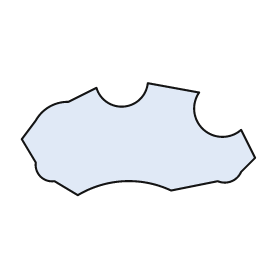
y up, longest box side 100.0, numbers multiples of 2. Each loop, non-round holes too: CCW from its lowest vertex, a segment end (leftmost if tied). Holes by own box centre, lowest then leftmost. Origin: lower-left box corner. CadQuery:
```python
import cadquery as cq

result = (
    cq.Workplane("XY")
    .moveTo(24.0, 0.0)
    .threePointArc((44.0, 6.0), (64.0, 2.0))
    .lineTo(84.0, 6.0)
    .threePointArc((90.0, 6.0), (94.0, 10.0))
    .lineTo(100.0, 16.0)
    .lineTo(94.0, 28.0)
    .threePointArc((78.0, 28.0), (76.0, 44.0))
    .lineTo(54.0, 48.0)
    .threePointArc((44.0, 38.0), (32.0, 46.0))
    .lineTo(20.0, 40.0)
    .threePointArc((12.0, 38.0), (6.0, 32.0))
    .lineTo(0.0, 24.0)
    .lineTo(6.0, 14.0)
    .threePointArc((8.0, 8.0), (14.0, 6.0))
    .close()
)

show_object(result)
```